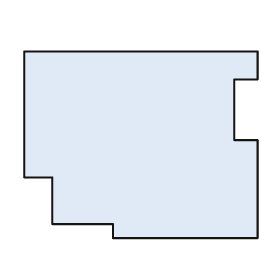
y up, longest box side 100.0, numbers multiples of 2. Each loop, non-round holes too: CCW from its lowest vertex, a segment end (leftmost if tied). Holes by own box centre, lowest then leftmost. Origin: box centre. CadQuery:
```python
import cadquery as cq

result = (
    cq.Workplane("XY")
    .moveTo(-12.0, -40.0)
    .lineTo(50.0, -40.0)
    .lineTo(50.0, 2.0)
    .lineTo(40.0, 2.0)
    .lineTo(40.0, 28.0)
    .lineTo(50.0, 28.0)
    .lineTo(50.0, 40.0)
    .lineTo(-50.0, 40.0)
    .lineTo(-50.0, -14.0)
    .lineTo(-38.0, -14.0)
    .lineTo(-38.0, -34.0)
    .lineTo(-12.0, -34.0)
    .close()
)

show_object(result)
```